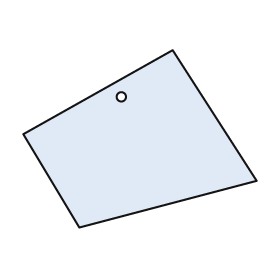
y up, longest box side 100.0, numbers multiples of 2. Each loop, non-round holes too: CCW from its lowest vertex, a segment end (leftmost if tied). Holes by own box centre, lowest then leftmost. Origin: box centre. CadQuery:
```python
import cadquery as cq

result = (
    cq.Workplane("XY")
    .moveTo(-26.0, -38.0)
    .lineTo(50.0, -18.0)
    .lineTo(14.0, 38.0)
    .lineTo(-50.0, 2.0)
    .close()
    .moveTo(-8.0, 18.0)
    .circle(2.0)
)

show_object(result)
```